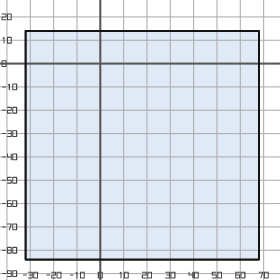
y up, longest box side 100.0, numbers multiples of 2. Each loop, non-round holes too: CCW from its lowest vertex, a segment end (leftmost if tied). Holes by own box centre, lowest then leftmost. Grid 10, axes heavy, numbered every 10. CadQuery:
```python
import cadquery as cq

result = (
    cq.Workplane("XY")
    .moveTo(-32.0, -84.0)
    .lineTo(68.0, -84.0)
    .lineTo(68.0, 14.0)
    .lineTo(-32.0, 14.0)
    .close()
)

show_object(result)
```